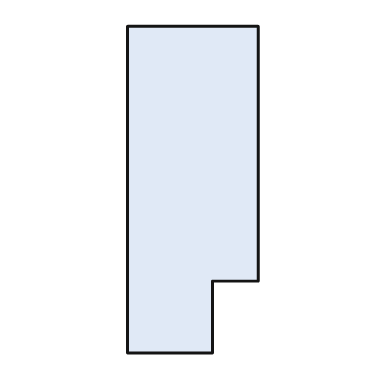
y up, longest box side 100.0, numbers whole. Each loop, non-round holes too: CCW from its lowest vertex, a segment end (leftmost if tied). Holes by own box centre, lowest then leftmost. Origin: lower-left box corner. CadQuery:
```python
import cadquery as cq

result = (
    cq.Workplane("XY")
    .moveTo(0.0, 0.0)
    .lineTo(26.0, 0.0)
    .lineTo(26.0, 22.0)
    .lineTo(40.0, 22.0)
    .lineTo(40.0, 100.0)
    .lineTo(0.0, 100.0)
    .close()
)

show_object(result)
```